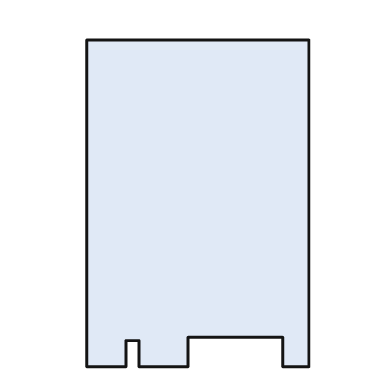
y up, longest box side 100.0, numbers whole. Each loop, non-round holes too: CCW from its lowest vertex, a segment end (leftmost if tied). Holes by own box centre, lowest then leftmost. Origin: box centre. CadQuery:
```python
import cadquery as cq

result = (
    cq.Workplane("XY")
    .moveTo(-34.0, -50.0)
    .lineTo(-22.0, -50.0)
    .lineTo(-22.0, -42.0)
    .lineTo(-18.0, -42.0)
    .lineTo(-18.0, -50.0)
    .lineTo(-3.0, -50.0)
    .lineTo(-3.0, -41.0)
    .lineTo(26.0, -41.0)
    .lineTo(26.0, -50.0)
    .lineTo(34.0, -50.0)
    .lineTo(34.0, 50.0)
    .lineTo(-34.0, 50.0)
    .close()
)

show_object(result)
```